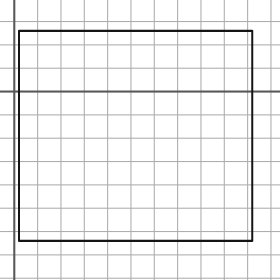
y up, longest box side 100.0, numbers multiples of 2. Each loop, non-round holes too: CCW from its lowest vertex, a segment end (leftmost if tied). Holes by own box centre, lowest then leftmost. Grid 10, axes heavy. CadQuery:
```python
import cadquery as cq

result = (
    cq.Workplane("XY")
    .moveTo(2.0, -64.0)
    .lineTo(102.0, -64.0)
    .lineTo(102.0, 26.0)
    .lineTo(2.0, 26.0)
    .close()
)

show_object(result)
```